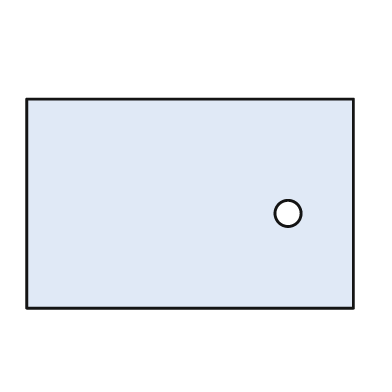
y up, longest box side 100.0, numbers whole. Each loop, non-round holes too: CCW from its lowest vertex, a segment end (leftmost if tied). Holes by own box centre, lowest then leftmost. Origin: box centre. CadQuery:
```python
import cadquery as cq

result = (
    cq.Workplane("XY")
    .moveTo(-50.0, -32.0)
    .lineTo(50.0, -32.0)
    .lineTo(50.0, 32.0)
    .lineTo(-50.0, 32.0)
    .close()
    .moveTo(30.0, -3.0)
    .circle(4.0)
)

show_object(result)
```